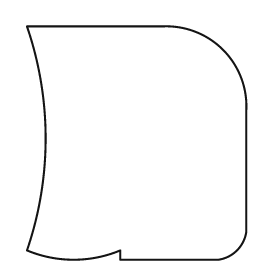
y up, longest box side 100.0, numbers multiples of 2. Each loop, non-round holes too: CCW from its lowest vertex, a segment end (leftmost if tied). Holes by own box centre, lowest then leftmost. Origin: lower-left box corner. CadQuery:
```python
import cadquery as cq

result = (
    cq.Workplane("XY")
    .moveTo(40.0, 0.0)
    .lineTo(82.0, 0.0)
    .threePointArc((90.0, 4.0), (94.0, 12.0))
    .lineTo(94.0, 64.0)
    .threePointArc((84.0, 90.0), (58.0, 100.0))
    .lineTo(0.0, 100.0)
    .threePointArc((8.0, 52.0), (0.0, 4.0))
    .threePointArc((20.0, 0.0), (40.0, 4.0))
    .close()
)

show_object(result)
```